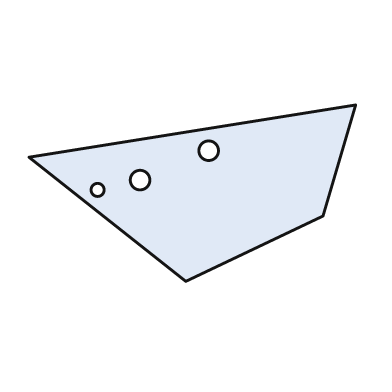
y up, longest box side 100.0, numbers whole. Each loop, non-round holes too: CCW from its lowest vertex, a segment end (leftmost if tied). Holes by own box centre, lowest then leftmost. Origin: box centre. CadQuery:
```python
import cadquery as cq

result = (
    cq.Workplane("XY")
    .moveTo(-2.0, -27.0)
    .lineTo(40.0, -7.0)
    .lineTo(50.0, 27.0)
    .lineTo(-50.0, 11.0)
    .close()
    .moveTo(-29.0, 1.0)
    .circle(2.0)
    .moveTo(-16.0, 4.0)
    .circle(3.0)
    .moveTo(5.0, 13.0)
    .circle(3.0)
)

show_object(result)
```